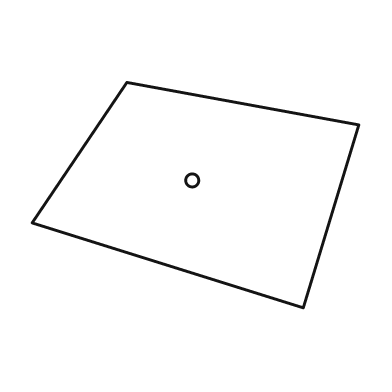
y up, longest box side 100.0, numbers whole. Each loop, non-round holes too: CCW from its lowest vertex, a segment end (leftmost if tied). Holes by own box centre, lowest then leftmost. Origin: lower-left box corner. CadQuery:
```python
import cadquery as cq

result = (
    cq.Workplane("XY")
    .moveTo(83.0, 0.0)
    .lineTo(100.0, 56.0)
    .lineTo(29.0, 69.0)
    .lineTo(0.0, 26.0)
    .close()
    .moveTo(49.0, 39.0)
    .circle(2.0)
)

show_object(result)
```